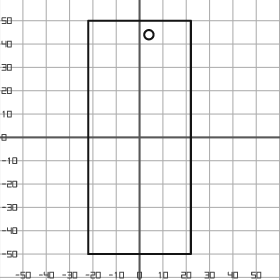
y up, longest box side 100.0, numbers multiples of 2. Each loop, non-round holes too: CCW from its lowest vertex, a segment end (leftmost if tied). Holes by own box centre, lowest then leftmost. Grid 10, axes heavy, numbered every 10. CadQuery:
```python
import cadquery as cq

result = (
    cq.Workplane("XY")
    .moveTo(-22.0, -50.0)
    .lineTo(22.0, -50.0)
    .lineTo(22.0, 50.0)
    .lineTo(-22.0, 50.0)
    .close()
    .moveTo(4.0, 44.0)
    .circle(2.0)
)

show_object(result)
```